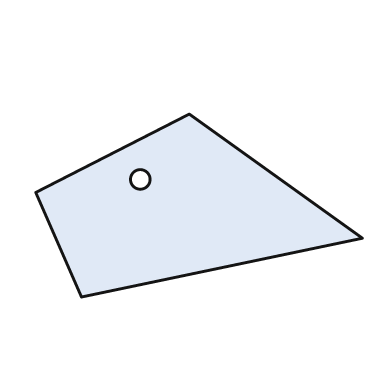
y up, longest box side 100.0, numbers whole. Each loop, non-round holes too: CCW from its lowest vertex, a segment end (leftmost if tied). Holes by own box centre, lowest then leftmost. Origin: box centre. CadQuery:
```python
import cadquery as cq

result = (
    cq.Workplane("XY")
    .moveTo(-36.0, -28.0)
    .lineTo(50.0, -10.0)
    .lineTo(-3.0, 28.0)
    .lineTo(-50.0, 4.0)
    .close()
    .moveTo(-18.0, 8.0)
    .circle(3.0)
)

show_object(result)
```